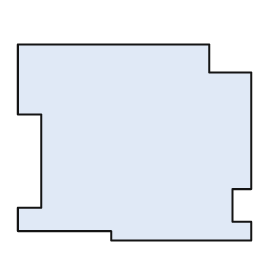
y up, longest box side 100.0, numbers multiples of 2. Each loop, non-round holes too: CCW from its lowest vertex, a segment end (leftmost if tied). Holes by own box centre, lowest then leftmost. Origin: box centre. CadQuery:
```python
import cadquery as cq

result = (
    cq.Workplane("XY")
    .moveTo(-10.0, -42.0)
    .lineTo(50.0, -42.0)
    .lineTo(50.0, -34.0)
    .lineTo(42.0, -34.0)
    .lineTo(42.0, -20.0)
    .lineTo(50.0, -20.0)
    .lineTo(50.0, 30.0)
    .lineTo(32.0, 30.0)
    .lineTo(32.0, 42.0)
    .lineTo(-50.0, 42.0)
    .lineTo(-50.0, 12.0)
    .lineTo(-40.0, 12.0)
    .lineTo(-40.0, -28.0)
    .lineTo(-50.0, -28.0)
    .lineTo(-50.0, -38.0)
    .lineTo(-10.0, -38.0)
    .close()
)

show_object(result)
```